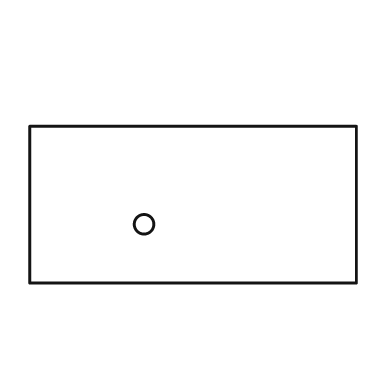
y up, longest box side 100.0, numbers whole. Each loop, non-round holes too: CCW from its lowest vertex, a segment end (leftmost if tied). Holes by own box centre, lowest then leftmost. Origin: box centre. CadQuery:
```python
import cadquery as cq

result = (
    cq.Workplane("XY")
    .moveTo(-50.0, -24.0)
    .lineTo(50.0, -24.0)
    .lineTo(50.0, 24.0)
    .lineTo(-50.0, 24.0)
    .close()
    .moveTo(-15.0, -6.0)
    .circle(3.0)
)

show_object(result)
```